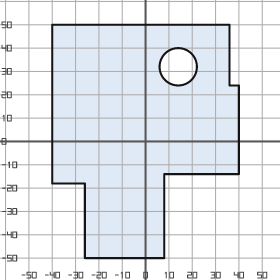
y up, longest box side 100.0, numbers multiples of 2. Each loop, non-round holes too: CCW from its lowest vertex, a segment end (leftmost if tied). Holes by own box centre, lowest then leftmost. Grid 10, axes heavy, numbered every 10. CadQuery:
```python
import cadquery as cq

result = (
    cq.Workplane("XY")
    .moveTo(-26.0, -50.0)
    .lineTo(8.0, -50.0)
    .lineTo(8.0, -14.0)
    .lineTo(40.0, -14.0)
    .lineTo(40.0, 24.0)
    .lineTo(36.0, 24.0)
    .lineTo(36.0, 50.0)
    .lineTo(-40.0, 50.0)
    .lineTo(-40.0, -18.0)
    .lineTo(-26.0, -18.0)
    .close()
    .moveTo(14.0, 32.0)
    .circle(8.0)
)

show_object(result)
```